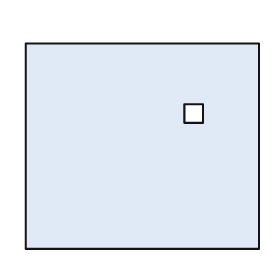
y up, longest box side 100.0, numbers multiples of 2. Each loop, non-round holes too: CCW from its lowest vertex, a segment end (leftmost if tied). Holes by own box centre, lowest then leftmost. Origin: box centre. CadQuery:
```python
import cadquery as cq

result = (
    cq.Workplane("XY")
    .moveTo(-50.0, -44.0)
    .lineTo(50.0, -44.0)
    .lineTo(50.0, 44.0)
    .lineTo(-50.0, 44.0)
    .close()
    .moveTo(18.0, 10.0)
    .lineTo(26.0, 10.0)
    .lineTo(26.0, 18.0)
    .lineTo(18.0, 18.0)
    .close()
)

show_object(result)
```